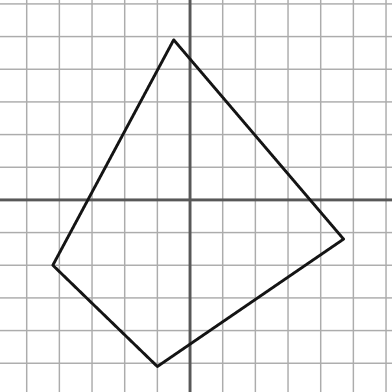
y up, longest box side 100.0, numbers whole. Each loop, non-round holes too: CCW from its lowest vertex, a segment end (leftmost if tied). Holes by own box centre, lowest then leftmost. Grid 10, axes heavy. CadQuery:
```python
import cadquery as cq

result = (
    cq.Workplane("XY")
    .moveTo(-10.0, -51.0)
    .lineTo(47.0, -12.0)
    .lineTo(-5.0, 49.0)
    .lineTo(-42.0, -20.0)
    .close()
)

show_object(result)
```